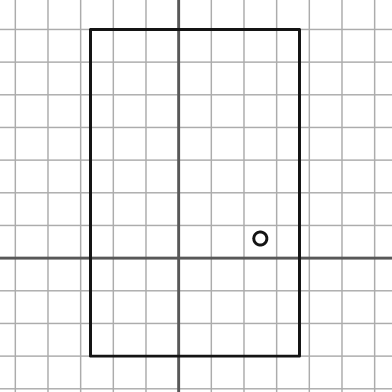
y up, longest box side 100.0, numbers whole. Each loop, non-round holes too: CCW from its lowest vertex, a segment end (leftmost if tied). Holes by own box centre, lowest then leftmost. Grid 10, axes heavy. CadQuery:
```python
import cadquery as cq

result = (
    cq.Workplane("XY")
    .moveTo(-27.0, -30.0)
    .lineTo(37.0, -30.0)
    .lineTo(37.0, 70.0)
    .lineTo(-27.0, 70.0)
    .close()
    .moveTo(25.0, 6.0)
    .circle(2.0)
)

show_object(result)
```